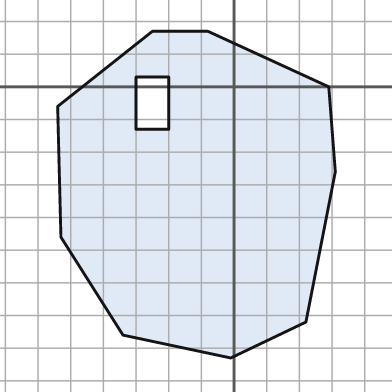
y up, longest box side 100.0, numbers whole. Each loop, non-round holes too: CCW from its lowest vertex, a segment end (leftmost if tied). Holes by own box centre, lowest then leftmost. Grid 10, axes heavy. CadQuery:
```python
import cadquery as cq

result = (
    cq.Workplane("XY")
    .moveTo(-1.0, -83.0)
    .lineTo(22.0, -72.0)
    .lineTo(31.0, -26.0)
    .lineTo(29.0, 0.0)
    .lineTo(-8.0, 17.0)
    .lineTo(-25.0, 17.0)
    .lineTo(-54.0, -6.0)
    .lineTo(-53.0, -46.0)
    .lineTo(-34.0, -76.0)
    .close()
    .moveTo(-30.0, -13.0)
    .lineTo(-20.0, -13.0)
    .lineTo(-20.0, 3.0)
    .lineTo(-30.0, 3.0)
    .close()
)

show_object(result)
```